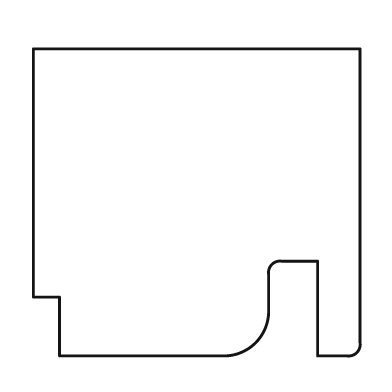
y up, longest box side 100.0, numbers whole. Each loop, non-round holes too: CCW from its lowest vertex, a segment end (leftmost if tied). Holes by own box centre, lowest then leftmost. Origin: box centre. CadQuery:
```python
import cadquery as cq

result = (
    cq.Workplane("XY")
    .moveTo(-42.0, -47.0)
    .lineTo(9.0, -47.0)
    .threePointArc((18.0, -43.0), (22.0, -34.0))
    .lineTo(22.0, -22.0)
    .threePointArc((23.0, -19.0), (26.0, -18.0))
    .lineTo(37.0, -18.0)
    .lineTo(37.0, -47.0)
    .lineTo(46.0, -47.0)
    .threePointArc((49.0, -46.0), (50.0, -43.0))
    .lineTo(50.0, 47.0)
    .lineTo(-50.0, 47.0)
    .lineTo(-50.0, -29.0)
    .lineTo(-42.0, -29.0)
    .close()
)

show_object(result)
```